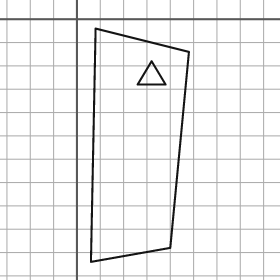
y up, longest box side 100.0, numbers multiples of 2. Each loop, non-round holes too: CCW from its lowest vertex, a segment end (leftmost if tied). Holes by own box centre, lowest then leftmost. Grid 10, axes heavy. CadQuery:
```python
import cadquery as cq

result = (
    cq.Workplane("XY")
    .moveTo(6.0, -104.0)
    .lineTo(40.0, -98.0)
    .lineTo(48.0, -14.0)
    .lineTo(8.0, -4.0)
    .close()
    .moveTo(26.0, -28.0)
    .lineTo(38.0, -28.0)
    .lineTo(32.0, -18.0)
    .close()
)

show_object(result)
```